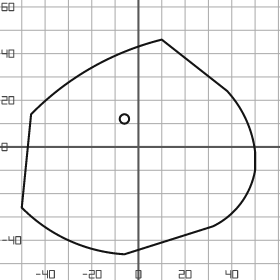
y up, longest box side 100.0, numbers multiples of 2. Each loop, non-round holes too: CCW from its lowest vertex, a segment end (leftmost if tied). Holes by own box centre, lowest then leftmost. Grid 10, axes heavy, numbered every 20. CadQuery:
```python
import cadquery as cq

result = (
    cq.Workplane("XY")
    .moveTo(-6.0, -46.0)
    .lineTo(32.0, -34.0)
    .threePointArc((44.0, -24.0), (50.0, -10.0))
    .lineTo(50.0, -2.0)
    .threePointArc((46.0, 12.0), (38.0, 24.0))
    .lineTo(10.0, 46.0)
    .threePointArc((-20.0, 34.0), (-46.0, 14.0))
    .lineTo(-50.0, -26.0)
    .threePointArc((-30.0, -40.0), (-6.0, -46.0))
    .close()
    .moveTo(-6.0, 12.0)
    .circle(2.0)
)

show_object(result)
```